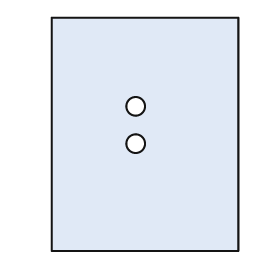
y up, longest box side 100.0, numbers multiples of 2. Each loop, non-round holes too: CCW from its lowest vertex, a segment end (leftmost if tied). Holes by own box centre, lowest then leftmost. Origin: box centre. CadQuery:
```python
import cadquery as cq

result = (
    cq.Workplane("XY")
    .moveTo(-40.0, -50.0)
    .lineTo(40.0, -50.0)
    .lineTo(40.0, 50.0)
    .lineTo(-40.0, 50.0)
    .close()
    .moveTo(-4.0, -4.0)
    .circle(4.0)
    .moveTo(-4.0, 12.0)
    .circle(4.0)
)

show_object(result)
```